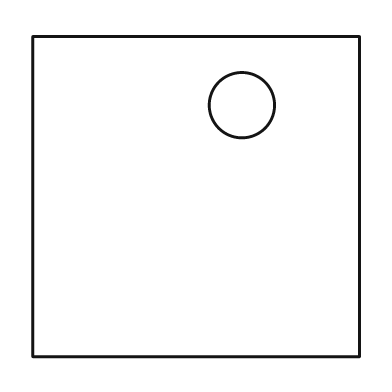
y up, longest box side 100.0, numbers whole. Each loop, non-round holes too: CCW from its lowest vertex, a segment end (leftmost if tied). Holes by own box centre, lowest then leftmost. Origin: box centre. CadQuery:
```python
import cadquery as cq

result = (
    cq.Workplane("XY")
    .moveTo(-50.0, -49.0)
    .lineTo(50.0, -49.0)
    .lineTo(50.0, 49.0)
    .lineTo(-50.0, 49.0)
    .close()
    .moveTo(14.0, 28.0)
    .circle(10.0)
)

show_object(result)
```